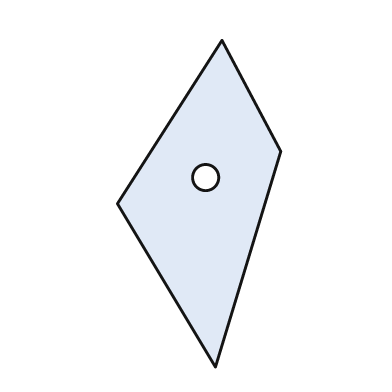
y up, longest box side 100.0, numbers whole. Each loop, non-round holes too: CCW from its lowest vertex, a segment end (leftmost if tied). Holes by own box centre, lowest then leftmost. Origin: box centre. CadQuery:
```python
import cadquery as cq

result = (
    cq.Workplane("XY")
    .moveTo(5.0, -50.0)
    .lineTo(25.0, 16.0)
    .lineTo(7.0, 50.0)
    .lineTo(-25.0, 0.0)
    .close()
    .moveTo(2.0, 8.0)
    .circle(4.0)
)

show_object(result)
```